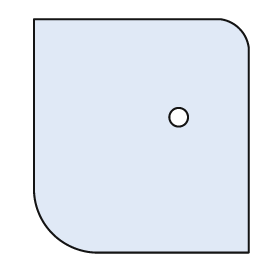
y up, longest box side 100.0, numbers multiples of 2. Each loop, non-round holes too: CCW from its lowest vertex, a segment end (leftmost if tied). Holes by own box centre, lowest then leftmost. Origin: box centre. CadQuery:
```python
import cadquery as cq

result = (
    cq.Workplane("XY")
    .moveTo(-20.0, -50.0)
    .lineTo(46.0, -50.0)
    .lineTo(46.0, 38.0)
    .threePointArc((42.0, 46.0), (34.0, 50.0))
    .lineTo(-46.0, 50.0)
    .lineTo(-46.0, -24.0)
    .threePointArc((-38.0, -42.0), (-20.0, -50.0))
    .close()
    .moveTo(16.0, 8.0)
    .circle(4.0)
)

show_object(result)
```